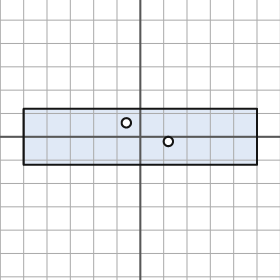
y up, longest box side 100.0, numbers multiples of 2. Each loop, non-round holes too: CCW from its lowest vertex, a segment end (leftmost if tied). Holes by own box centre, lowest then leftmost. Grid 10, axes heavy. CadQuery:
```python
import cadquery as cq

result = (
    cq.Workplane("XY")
    .moveTo(-50.0, -12.0)
    .lineTo(50.0, -12.0)
    .lineTo(50.0, 12.0)
    .lineTo(-50.0, 12.0)
    .close()
    .moveTo(12.0, -2.0)
    .circle(2.0)
    .moveTo(-6.0, 6.0)
    .circle(2.0)
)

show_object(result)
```